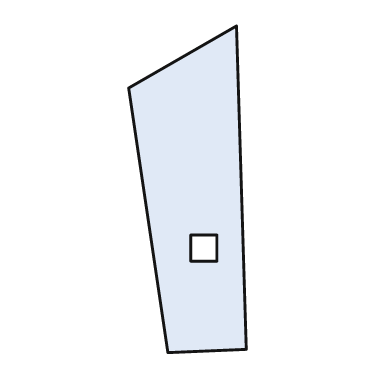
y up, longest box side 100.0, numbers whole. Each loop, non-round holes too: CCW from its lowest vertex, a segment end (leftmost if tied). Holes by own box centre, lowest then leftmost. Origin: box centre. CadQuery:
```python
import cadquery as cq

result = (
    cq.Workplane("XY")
    .moveTo(-6.0, -50.0)
    .lineTo(18.0, -49.0)
    .lineTo(15.0, 50.0)
    .lineTo(-18.0, 31.0)
    .close()
    .moveTo(1.0, -22.0)
    .lineTo(9.0, -22.0)
    .lineTo(9.0, -14.0)
    .lineTo(1.0, -14.0)
    .close()
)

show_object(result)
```